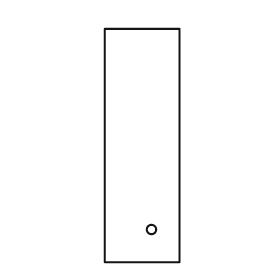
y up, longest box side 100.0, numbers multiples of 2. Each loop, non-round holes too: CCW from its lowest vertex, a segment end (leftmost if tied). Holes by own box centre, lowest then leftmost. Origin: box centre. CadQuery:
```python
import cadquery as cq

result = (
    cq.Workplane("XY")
    .moveTo(-16.0, -50.0)
    .lineTo(16.0, -50.0)
    .lineTo(16.0, 50.0)
    .lineTo(-16.0, 50.0)
    .close()
    .moveTo(4.0, -36.0)
    .circle(2.0)
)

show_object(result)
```